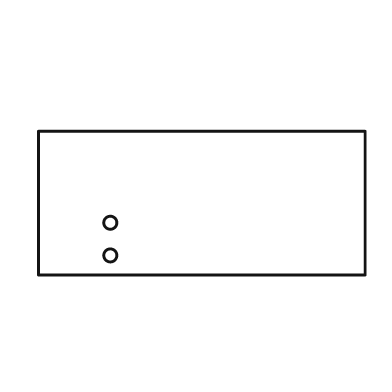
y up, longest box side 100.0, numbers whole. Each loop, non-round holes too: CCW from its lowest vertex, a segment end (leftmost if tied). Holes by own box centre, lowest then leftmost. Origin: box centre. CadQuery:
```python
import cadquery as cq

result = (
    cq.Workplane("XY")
    .moveTo(-50.0, -22.0)
    .lineTo(50.0, -22.0)
    .lineTo(50.0, 22.0)
    .lineTo(-50.0, 22.0)
    .close()
    .moveTo(-28.0, -16.0)
    .circle(2.0)
    .moveTo(-28.0, -6.0)
    .circle(2.0)
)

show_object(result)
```